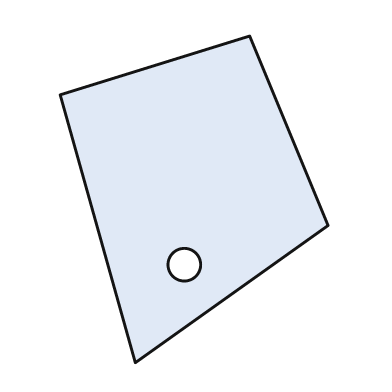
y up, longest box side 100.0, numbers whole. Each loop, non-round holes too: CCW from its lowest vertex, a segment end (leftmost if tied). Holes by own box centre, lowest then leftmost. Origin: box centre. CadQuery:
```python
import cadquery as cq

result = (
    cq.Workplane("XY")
    .moveTo(-18.0, -50.0)
    .lineTo(41.0, -8.0)
    .lineTo(17.0, 50.0)
    .lineTo(-41.0, 32.0)
    .close()
    .moveTo(-3.0, -20.0)
    .circle(5.0)
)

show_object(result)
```